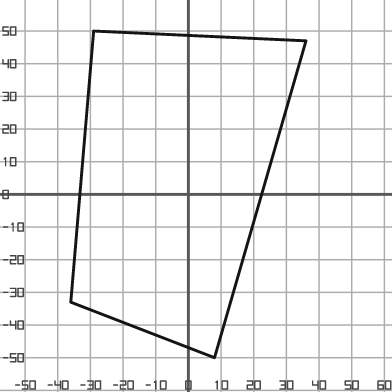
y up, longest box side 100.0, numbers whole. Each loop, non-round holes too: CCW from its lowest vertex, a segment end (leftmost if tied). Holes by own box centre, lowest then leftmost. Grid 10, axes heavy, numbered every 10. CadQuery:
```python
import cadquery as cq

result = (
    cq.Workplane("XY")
    .moveTo(8.0, -50.0)
    .lineTo(36.0, 47.0)
    .lineTo(-29.0, 50.0)
    .lineTo(-36.0, -33.0)
    .close()
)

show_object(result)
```